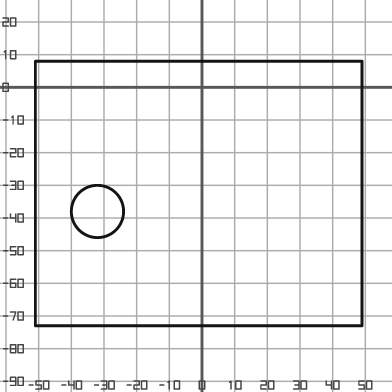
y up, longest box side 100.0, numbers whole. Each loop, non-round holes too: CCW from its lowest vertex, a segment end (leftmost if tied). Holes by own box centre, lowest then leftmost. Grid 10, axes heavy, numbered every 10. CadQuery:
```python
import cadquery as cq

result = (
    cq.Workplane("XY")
    .moveTo(-51.0, -73.0)
    .lineTo(49.0, -73.0)
    .lineTo(49.0, 8.0)
    .lineTo(-51.0, 8.0)
    .close()
    .moveTo(-32.0, -38.0)
    .circle(8.0)
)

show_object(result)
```